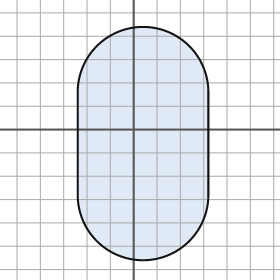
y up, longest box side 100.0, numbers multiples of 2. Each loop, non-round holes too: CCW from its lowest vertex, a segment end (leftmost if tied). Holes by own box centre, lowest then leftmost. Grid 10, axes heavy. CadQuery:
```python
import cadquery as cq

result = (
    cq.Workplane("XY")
    .moveTo(-24.0, -28.0)
    .threePointArc((4.0, -56.0), (32.0, -28.0))
    .lineTo(32.0, 16.0)
    .threePointArc((4.0, 44.0), (-24.0, 16.0))
    .close()
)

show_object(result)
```